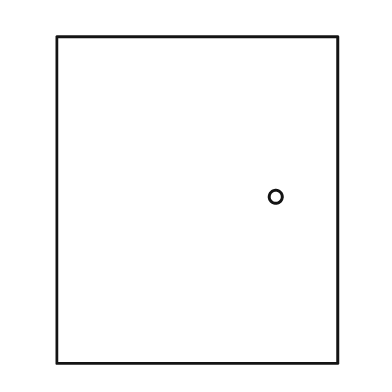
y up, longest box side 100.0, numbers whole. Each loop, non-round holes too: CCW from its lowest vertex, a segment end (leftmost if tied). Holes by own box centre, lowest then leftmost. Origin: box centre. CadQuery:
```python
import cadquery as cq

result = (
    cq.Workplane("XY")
    .moveTo(-43.0, -50.0)
    .lineTo(43.0, -50.0)
    .lineTo(43.0, 50.0)
    .lineTo(-43.0, 50.0)
    .close()
    .moveTo(24.0, 1.0)
    .circle(2.0)
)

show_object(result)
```